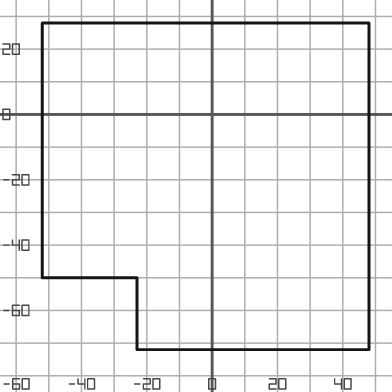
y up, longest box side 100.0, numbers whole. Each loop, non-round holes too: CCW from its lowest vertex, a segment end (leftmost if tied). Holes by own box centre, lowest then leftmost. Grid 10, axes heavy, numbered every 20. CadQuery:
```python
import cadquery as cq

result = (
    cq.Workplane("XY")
    .moveTo(-23.0, -72.0)
    .lineTo(48.0, -72.0)
    .lineTo(48.0, 28.0)
    .lineTo(-52.0, 28.0)
    .lineTo(-52.0, -50.0)
    .lineTo(-23.0, -50.0)
    .close()
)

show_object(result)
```